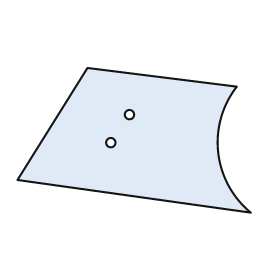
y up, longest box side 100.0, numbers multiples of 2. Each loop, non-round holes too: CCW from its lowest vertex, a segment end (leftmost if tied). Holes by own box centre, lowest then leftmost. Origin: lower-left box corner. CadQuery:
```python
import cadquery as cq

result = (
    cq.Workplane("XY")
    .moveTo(100.0, 0.0)
    .threePointArc((86.0, 26.0), (94.0, 54.0))
    .lineTo(30.0, 62.0)
    .lineTo(0.0, 14.0)
    .close()
    .moveTo(40.0, 30.0)
    .circle(2.0)
    .moveTo(48.0, 42.0)
    .circle(2.0)
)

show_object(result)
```